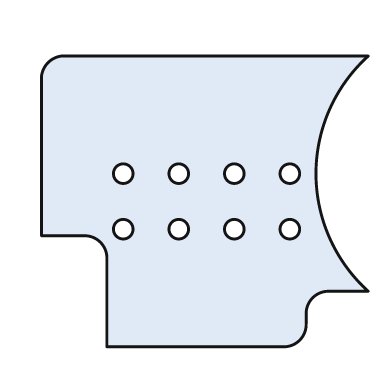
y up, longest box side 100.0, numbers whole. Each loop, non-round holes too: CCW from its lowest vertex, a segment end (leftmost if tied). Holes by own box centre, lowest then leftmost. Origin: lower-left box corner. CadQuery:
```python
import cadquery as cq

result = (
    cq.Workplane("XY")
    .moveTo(20.0, 0.0)
    .lineTo(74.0, 0.0)
    .threePointArc((79.0, 2.0), (81.0, 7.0))
    .lineTo(81.0, 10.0)
    .threePointArc((83.0, 15.0), (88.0, 17.0))
    .lineTo(100.0, 17.0)
    .threePointArc((84.0, 53.0), (100.0, 89.0))
    .lineTo(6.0, 89.0)
    .threePointArc((2.0, 87.0), (0.0, 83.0))
    .lineTo(0.0, 34.0)
    .lineTo(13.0, 34.0)
    .threePointArc((18.0, 32.0), (20.0, 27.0))
    .close()
    .moveTo(25.0, 36.0)
    .circle(3.0)
    .moveTo(42.0, 36.0)
    .circle(3.0)
    .moveTo(59.0, 36.0)
    .circle(3.0)
    .moveTo(76.0, 36.0)
    .circle(3.0)
    .moveTo(25.0, 53.0)
    .circle(3.0)
    .moveTo(42.0, 53.0)
    .circle(3.0)
    .moveTo(59.0, 53.0)
    .circle(3.0)
    .moveTo(76.0, 53.0)
    .circle(3.0)
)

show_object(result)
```